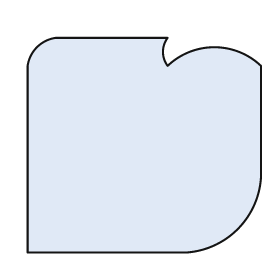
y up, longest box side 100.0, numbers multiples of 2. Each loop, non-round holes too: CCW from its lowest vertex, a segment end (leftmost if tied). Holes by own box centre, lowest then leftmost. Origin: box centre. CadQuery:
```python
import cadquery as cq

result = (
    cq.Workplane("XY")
    .moveTo(-50.0, -46.0)
    .lineTo(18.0, -46.0)
    .threePointArc((40.0, -36.0), (50.0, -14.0))
    .lineTo(50.0, 34.0)
    .threePointArc((30.0, 42.0), (10.0, 34.0))
    .threePointArc((8.0, 40.0), (10.0, 46.0))
    .lineTo(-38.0, 46.0)
    .threePointArc((-46.0, 42.0), (-50.0, 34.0))
    .close()
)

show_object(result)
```